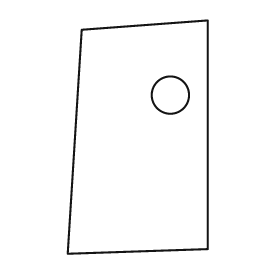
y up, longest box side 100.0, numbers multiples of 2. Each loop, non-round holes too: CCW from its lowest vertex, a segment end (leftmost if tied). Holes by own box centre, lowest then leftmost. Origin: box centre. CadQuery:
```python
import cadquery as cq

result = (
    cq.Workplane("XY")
    .moveTo(-30.0, -50.0)
    .lineTo(30.0, -48.0)
    .lineTo(30.0, 50.0)
    .lineTo(-24.0, 46.0)
    .close()
    .moveTo(14.0, 18.0)
    .circle(8.0)
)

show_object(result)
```